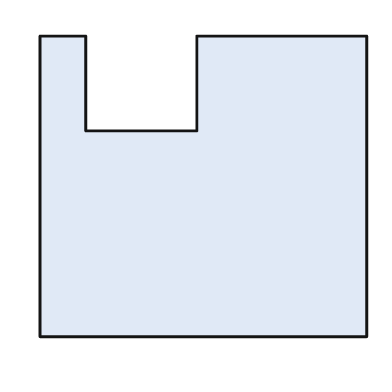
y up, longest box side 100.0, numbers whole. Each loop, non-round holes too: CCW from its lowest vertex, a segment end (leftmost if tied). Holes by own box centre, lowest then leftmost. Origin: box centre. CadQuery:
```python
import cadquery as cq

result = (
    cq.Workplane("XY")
    .moveTo(-50.0, -46.0)
    .lineTo(50.0, -46.0)
    .lineTo(50.0, 46.0)
    .lineTo(-2.0, 46.0)
    .lineTo(-2.0, 17.0)
    .lineTo(-36.0, 17.0)
    .lineTo(-36.0, 46.0)
    .lineTo(-50.0, 46.0)
    .close()
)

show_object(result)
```